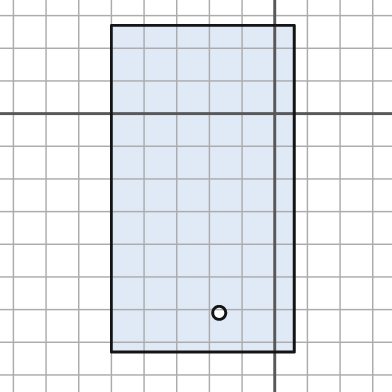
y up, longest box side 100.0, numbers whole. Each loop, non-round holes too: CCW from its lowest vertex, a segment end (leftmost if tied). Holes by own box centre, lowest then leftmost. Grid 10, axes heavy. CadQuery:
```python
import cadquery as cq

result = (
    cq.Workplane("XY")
    .moveTo(-50.0, -73.0)
    .lineTo(6.0, -73.0)
    .lineTo(6.0, 27.0)
    .lineTo(-50.0, 27.0)
    .close()
    .moveTo(-17.0, -61.0)
    .circle(2.0)
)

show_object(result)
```